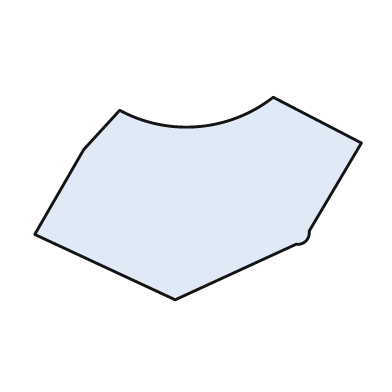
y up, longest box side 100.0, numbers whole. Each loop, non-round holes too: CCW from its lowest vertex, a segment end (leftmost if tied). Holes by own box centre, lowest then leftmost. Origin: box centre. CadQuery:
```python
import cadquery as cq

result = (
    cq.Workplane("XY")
    .moveTo(-7.0, -31.0)
    .lineTo(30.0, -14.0)
    .threePointArc((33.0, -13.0), (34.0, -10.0))
    .lineTo(50.0, 17.0)
    .lineTo(23.0, 31.0)
    .threePointArc((0.0, 22.0), (-24.0, 27.0))
    .lineTo(-35.0, 15.0)
    .lineTo(-50.0, -11.0)
    .close()
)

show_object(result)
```